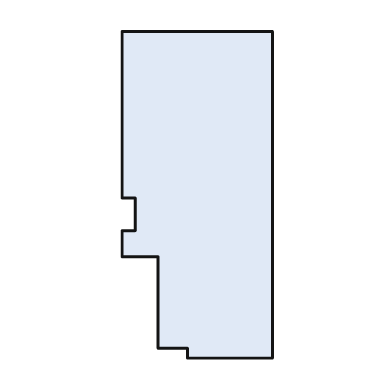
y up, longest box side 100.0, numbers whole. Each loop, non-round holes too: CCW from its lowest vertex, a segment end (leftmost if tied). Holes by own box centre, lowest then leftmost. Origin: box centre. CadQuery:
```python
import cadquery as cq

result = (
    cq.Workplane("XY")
    .moveTo(-3.0, -50.0)
    .lineTo(23.0, -50.0)
    .lineTo(23.0, 50.0)
    .lineTo(-23.0, 50.0)
    .lineTo(-23.0, -1.0)
    .lineTo(-19.0, -1.0)
    .lineTo(-19.0, -11.0)
    .lineTo(-23.0, -11.0)
    .lineTo(-23.0, -19.0)
    .lineTo(-12.0, -19.0)
    .lineTo(-12.0, -47.0)
    .lineTo(-3.0, -47.0)
    .close()
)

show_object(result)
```